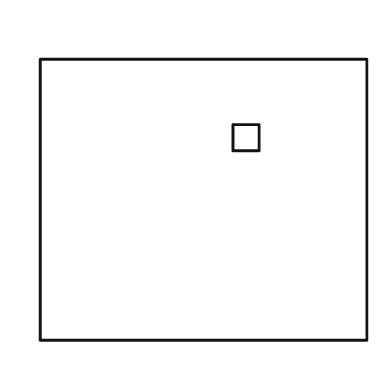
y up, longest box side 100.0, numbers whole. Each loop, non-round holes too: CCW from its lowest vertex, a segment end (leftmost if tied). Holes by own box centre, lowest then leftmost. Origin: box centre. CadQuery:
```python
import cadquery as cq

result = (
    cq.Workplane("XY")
    .moveTo(-50.0, -43.0)
    .lineTo(50.0, -43.0)
    .lineTo(50.0, 43.0)
    .lineTo(-50.0, 43.0)
    .close()
    .moveTo(9.0, 15.0)
    .lineTo(17.0, 15.0)
    .lineTo(17.0, 23.0)
    .lineTo(9.0, 23.0)
    .close()
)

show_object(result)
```